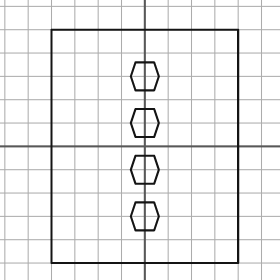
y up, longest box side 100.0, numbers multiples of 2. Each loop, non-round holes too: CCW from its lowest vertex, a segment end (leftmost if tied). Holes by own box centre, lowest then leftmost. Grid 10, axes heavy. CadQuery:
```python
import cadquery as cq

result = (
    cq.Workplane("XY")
    .moveTo(-40.0, -50.0)
    .lineTo(40.0, -50.0)
    .lineTo(40.0, 50.0)
    .lineTo(-40.0, 50.0)
    .close()
    .moveTo(-4.0, -36.0)
    .lineTo(4.0, -36.0)
    .lineTo(6.0, -30.0)
    .lineTo(4.0, -24.0)
    .lineTo(-4.0, -24.0)
    .lineTo(-6.0, -30.0)
    .close()
    .moveTo(-4.0, -16.0)
    .lineTo(4.0, -16.0)
    .lineTo(6.0, -10.0)
    .lineTo(4.0, -4.0)
    .lineTo(-4.0, -4.0)
    .lineTo(-6.0, -10.0)
    .close()
    .moveTo(-4.0, 4.0)
    .lineTo(4.0, 4.0)
    .lineTo(6.0, 10.0)
    .lineTo(4.0, 16.0)
    .lineTo(-4.0, 16.0)
    .lineTo(-6.0, 10.0)
    .close()
    .moveTo(-4.0, 24.0)
    .lineTo(4.0, 24.0)
    .lineTo(6.0, 30.0)
    .lineTo(4.0, 36.0)
    .lineTo(-4.0, 36.0)
    .lineTo(-6.0, 30.0)
    .close()
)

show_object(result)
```